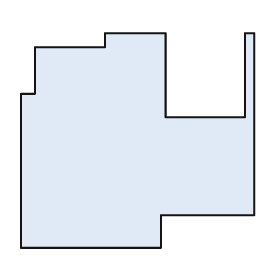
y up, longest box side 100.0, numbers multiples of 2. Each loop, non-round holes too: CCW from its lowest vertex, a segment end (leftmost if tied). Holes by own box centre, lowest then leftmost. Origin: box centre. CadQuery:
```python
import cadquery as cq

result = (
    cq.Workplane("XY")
    .moveTo(-50.0, -46.0)
    .lineTo(10.0, -46.0)
    .lineTo(10.0, -32.0)
    .lineTo(50.0, -32.0)
    .lineTo(50.0, 46.0)
    .lineTo(46.0, 46.0)
    .lineTo(46.0, 10.0)
    .lineTo(12.0, 10.0)
    .lineTo(12.0, 46.0)
    .lineTo(-14.0, 46.0)
    .lineTo(-14.0, 40.0)
    .lineTo(-44.0, 40.0)
    .lineTo(-44.0, 20.0)
    .lineTo(-50.0, 20.0)
    .close()
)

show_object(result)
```